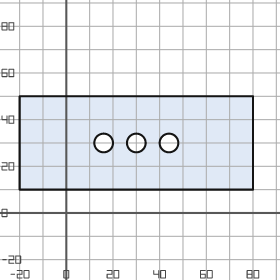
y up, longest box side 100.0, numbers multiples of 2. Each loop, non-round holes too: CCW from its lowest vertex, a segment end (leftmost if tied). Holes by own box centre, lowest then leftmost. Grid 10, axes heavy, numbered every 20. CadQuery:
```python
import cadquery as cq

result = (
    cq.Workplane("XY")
    .moveTo(-20.0, 10.0)
    .lineTo(80.0, 10.0)
    .lineTo(80.0, 50.0)
    .lineTo(-20.0, 50.0)
    .close()
    .moveTo(16.0, 30.0)
    .circle(4.0)
    .moveTo(30.0, 30.0)
    .circle(4.0)
    .moveTo(44.0, 30.0)
    .circle(4.0)
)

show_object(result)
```